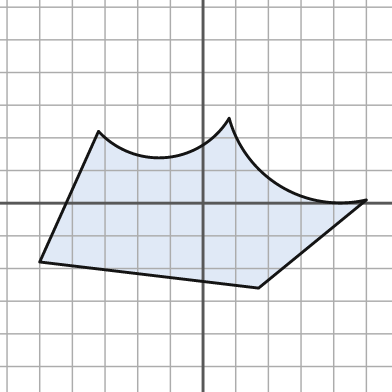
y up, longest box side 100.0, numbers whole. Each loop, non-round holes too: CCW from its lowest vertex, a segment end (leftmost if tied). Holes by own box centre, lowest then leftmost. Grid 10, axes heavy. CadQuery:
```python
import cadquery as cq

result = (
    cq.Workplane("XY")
    .moveTo(17.0, -26.0)
    .lineTo(50.0, 1.0)
    .threePointArc((24.0, 5.0), (8.0, 26.0))
    .threePointArc((-11.0, 14.0), (-32.0, 22.0))
    .lineTo(-50.0, -18.0)
    .close()
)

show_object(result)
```